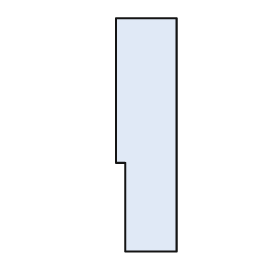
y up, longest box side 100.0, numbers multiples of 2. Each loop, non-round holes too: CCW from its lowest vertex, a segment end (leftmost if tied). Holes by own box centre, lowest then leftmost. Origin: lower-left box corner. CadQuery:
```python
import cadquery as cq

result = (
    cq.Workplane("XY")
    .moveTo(4.0, 0.0)
    .lineTo(26.0, 0.0)
    .lineTo(26.0, 100.0)
    .lineTo(0.0, 100.0)
    .lineTo(0.0, 38.0)
    .lineTo(4.0, 38.0)
    .close()
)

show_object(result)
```